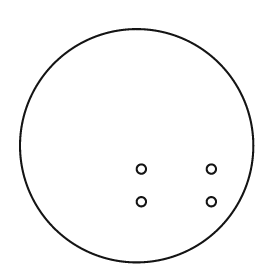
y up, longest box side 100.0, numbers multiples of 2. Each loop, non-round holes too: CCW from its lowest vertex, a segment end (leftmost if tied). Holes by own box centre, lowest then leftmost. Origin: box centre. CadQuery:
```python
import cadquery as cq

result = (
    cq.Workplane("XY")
    .moveTo(0.0, 0.0)
    .circle(50.0)
    .moveTo(2.0, -24.0)
    .circle(2.0)
    .moveTo(32.0, -24.0)
    .circle(2.0)
    .moveTo(2.0, -10.0)
    .circle(2.0)
    .moveTo(32.0, -10.0)
    .circle(2.0)
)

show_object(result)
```